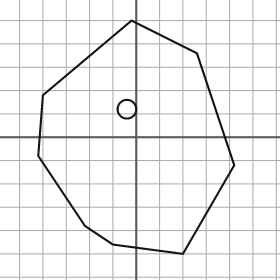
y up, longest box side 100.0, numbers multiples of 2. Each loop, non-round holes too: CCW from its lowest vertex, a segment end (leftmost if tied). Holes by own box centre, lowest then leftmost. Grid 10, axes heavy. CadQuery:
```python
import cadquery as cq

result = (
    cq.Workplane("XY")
    .moveTo(20.0, -50.0)
    .lineTo(42.0, -12.0)
    .lineTo(26.0, 36.0)
    .lineTo(-2.0, 50.0)
    .lineTo(-40.0, 18.0)
    .lineTo(-42.0, -8.0)
    .lineTo(-22.0, -38.0)
    .lineTo(-10.0, -46.0)
    .close()
    .moveTo(-4.0, 12.0)
    .circle(4.0)
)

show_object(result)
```